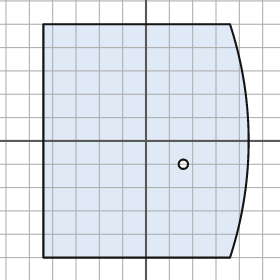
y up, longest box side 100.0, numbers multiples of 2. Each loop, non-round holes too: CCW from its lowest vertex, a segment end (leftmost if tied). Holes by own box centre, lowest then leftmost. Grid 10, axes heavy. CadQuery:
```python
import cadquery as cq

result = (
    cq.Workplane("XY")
    .moveTo(-44.0, -50.0)
    .lineTo(36.0, -50.0)
    .threePointArc((44.0, 0.0), (36.0, 50.0))
    .lineTo(-44.0, 50.0)
    .close()
    .moveTo(16.0, -10.0)
    .circle(2.0)
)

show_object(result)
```